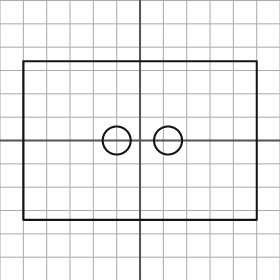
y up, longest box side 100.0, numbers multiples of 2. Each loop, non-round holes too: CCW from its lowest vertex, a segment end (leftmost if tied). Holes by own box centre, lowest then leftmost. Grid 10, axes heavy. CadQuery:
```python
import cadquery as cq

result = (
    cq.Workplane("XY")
    .moveTo(-50.0, -34.0)
    .lineTo(50.0, -34.0)
    .lineTo(50.0, 34.0)
    .lineTo(-50.0, 34.0)
    .close()
    .moveTo(-10.0, 0.0)
    .circle(6.0)
    .moveTo(12.0, 0.0)
    .circle(6.0)
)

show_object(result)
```